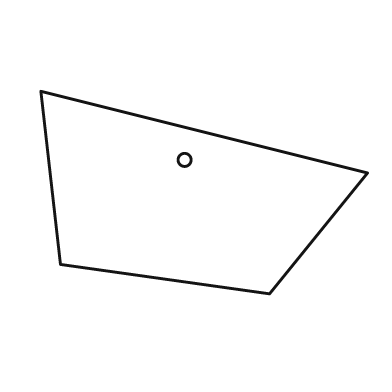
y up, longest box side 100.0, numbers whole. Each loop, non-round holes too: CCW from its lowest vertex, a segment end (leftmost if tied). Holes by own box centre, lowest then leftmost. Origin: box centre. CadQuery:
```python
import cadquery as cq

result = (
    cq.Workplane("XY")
    .moveTo(20.0, -31.0)
    .lineTo(50.0, 6.0)
    .lineTo(-50.0, 31.0)
    .lineTo(-44.0, -22.0)
    .close()
    .moveTo(-6.0, 10.0)
    .circle(2.0)
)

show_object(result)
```